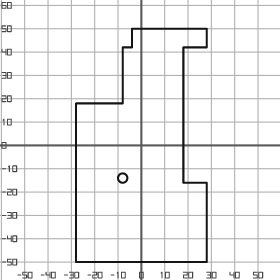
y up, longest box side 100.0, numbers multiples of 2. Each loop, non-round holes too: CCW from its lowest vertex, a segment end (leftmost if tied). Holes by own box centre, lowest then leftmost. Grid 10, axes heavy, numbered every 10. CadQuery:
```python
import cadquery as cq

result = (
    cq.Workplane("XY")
    .moveTo(-28.0, -50.0)
    .lineTo(28.0, -50.0)
    .lineTo(28.0, -16.0)
    .lineTo(18.0, -16.0)
    .lineTo(18.0, 42.0)
    .lineTo(28.0, 42.0)
    .lineTo(28.0, 50.0)
    .lineTo(-4.0, 50.0)
    .lineTo(-4.0, 42.0)
    .lineTo(-8.0, 42.0)
    .lineTo(-8.0, 18.0)
    .lineTo(-28.0, 18.0)
    .close()
    .moveTo(-8.0, -14.0)
    .circle(2.0)
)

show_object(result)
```